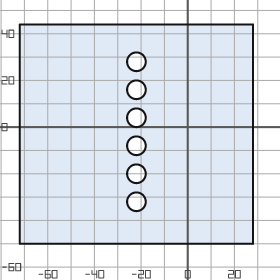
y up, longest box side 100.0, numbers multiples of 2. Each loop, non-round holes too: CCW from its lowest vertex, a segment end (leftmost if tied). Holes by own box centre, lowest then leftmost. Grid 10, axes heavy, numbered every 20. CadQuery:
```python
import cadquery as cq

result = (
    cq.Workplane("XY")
    .moveTo(-72.0, -50.0)
    .lineTo(28.0, -50.0)
    .lineTo(28.0, 44.0)
    .lineTo(-72.0, 44.0)
    .close()
    .moveTo(-22.0, -32.0)
    .circle(4.0)
    .moveTo(-22.0, -20.0)
    .circle(4.0)
    .moveTo(-22.0, -8.0)
    .circle(4.0)
    .moveTo(-22.0, 4.0)
    .circle(4.0)
    .moveTo(-22.0, 16.0)
    .circle(4.0)
    .moveTo(-22.0, 28.0)
    .circle(4.0)
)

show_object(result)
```